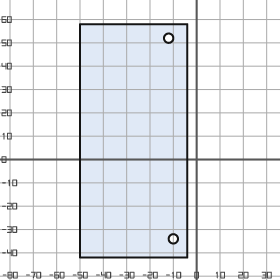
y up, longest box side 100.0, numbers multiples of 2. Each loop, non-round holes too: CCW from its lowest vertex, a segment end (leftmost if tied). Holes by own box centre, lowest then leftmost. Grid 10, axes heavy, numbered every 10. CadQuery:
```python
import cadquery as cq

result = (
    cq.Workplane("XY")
    .moveTo(-50.0, -42.0)
    .lineTo(-4.0, -42.0)
    .lineTo(-4.0, 58.0)
    .lineTo(-50.0, 58.0)
    .close()
    .moveTo(-10.0, -34.0)
    .circle(2.0)
    .moveTo(-12.0, 52.0)
    .circle(2.0)
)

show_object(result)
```